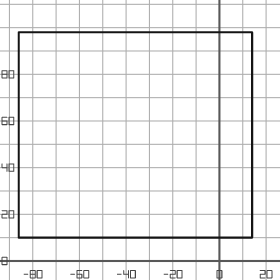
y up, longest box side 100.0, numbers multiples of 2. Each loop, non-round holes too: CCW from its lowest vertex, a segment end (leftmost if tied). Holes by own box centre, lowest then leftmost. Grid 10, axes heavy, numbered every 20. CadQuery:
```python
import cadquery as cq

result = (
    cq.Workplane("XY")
    .moveTo(-86.0, 10.0)
    .lineTo(14.0, 10.0)
    .lineTo(14.0, 98.0)
    .lineTo(-86.0, 98.0)
    .close()
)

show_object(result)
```